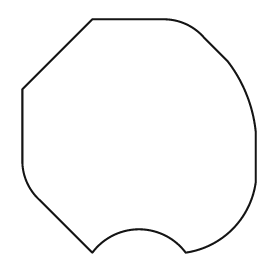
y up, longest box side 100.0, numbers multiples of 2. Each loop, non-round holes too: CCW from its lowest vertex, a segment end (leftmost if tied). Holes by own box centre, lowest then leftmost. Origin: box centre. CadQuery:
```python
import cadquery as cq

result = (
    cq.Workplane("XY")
    .moveTo(-20.0, -50.0)
    .threePointArc((0.0, -40.0), (20.0, -50.0))
    .threePointArc((40.0, -40.0), (50.0, -20.0))
    .lineTo(50.0, 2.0)
    .threePointArc((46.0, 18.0), (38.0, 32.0))
    .lineTo(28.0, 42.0)
    .threePointArc((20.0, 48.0), (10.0, 50.0))
    .lineTo(-20.0, 50.0)
    .lineTo(-50.0, 20.0)
    .lineTo(-50.0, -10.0)
    .threePointArc((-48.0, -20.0), (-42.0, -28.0))
    .close()
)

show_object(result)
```